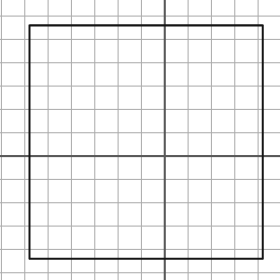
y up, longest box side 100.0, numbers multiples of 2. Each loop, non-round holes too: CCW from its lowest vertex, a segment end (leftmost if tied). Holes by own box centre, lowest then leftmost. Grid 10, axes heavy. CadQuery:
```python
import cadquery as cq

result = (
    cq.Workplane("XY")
    .moveTo(-58.0, -44.0)
    .lineTo(42.0, -44.0)
    .lineTo(42.0, 56.0)
    .lineTo(-58.0, 56.0)
    .close()
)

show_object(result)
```